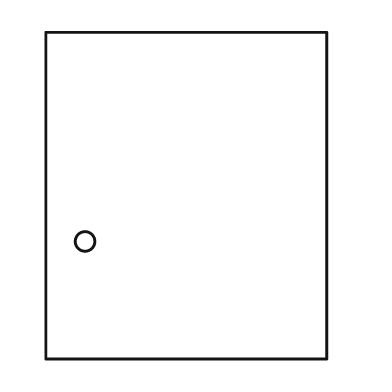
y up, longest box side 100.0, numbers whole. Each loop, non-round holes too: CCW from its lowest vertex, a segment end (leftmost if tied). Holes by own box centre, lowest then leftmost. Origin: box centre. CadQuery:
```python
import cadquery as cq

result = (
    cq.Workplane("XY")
    .moveTo(-43.0, -50.0)
    .lineTo(43.0, -50.0)
    .lineTo(43.0, 50.0)
    .lineTo(-43.0, 50.0)
    .close()
    .moveTo(-31.0, -14.0)
    .circle(3.0)
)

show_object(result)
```